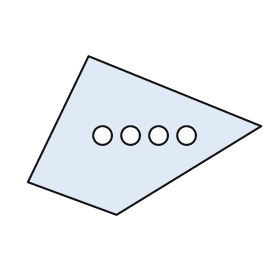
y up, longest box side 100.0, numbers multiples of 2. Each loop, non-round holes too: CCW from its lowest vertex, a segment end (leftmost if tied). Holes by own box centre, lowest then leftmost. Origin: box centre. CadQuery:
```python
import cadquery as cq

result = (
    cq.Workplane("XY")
    .moveTo(-12.0, -34.0)
    .lineTo(50.0, 4.0)
    .lineTo(-24.0, 34.0)
    .lineTo(-50.0, -20.0)
    .close()
    .moveTo(-18.0, 0.0)
    .circle(4.0)
    .moveTo(-6.0, 0.0)
    .circle(4.0)
    .moveTo(6.0, 0.0)
    .circle(4.0)
    .moveTo(18.0, 0.0)
    .circle(4.0)
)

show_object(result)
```